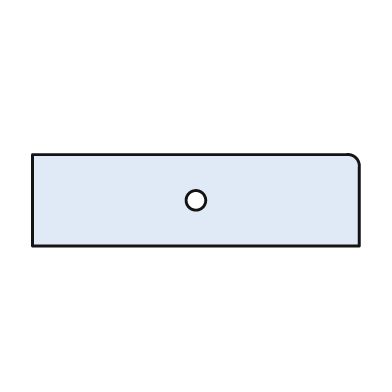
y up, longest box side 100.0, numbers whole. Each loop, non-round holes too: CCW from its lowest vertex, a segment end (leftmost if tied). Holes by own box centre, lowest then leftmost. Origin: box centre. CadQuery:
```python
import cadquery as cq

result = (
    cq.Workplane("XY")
    .moveTo(-50.0, -14.0)
    .lineTo(50.0, -14.0)
    .lineTo(50.0, 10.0)
    .threePointArc((49.0, 13.0), (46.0, 14.0))
    .lineTo(-50.0, 14.0)
    .close()
    .moveTo(0.0, 0.0)
    .circle(3.0)
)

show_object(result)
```